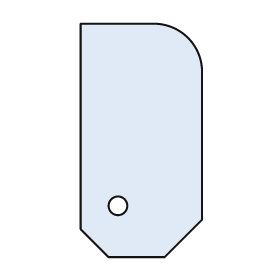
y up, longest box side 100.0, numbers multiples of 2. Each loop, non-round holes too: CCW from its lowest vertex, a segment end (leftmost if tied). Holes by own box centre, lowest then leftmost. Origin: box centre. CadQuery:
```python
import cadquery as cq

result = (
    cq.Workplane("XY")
    .moveTo(-14.0, -50.0)
    .lineTo(10.0, -50.0)
    .lineTo(26.0, -34.0)
    .lineTo(26.0, 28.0)
    .threePointArc((20.0, 44.0), (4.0, 50.0))
    .lineTo(-26.0, 50.0)
    .lineTo(-26.0, -38.0)
    .close()
    .moveTo(-10.0, -28.0)
    .circle(4.0)
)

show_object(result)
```